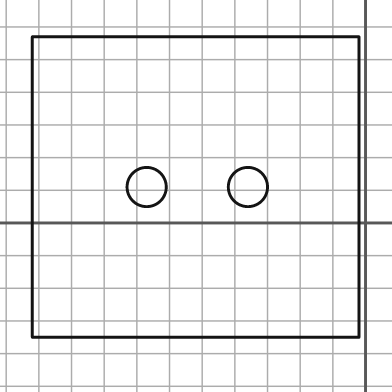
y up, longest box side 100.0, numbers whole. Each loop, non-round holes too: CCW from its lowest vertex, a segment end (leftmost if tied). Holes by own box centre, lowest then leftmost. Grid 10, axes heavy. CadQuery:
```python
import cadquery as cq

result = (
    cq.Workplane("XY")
    .moveTo(-102.0, -35.0)
    .lineTo(-2.0, -35.0)
    .lineTo(-2.0, 57.0)
    .lineTo(-102.0, 57.0)
    .close()
    .moveTo(-67.0, 11.0)
    .circle(6.0)
    .moveTo(-36.0, 11.0)
    .circle(6.0)
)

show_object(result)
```